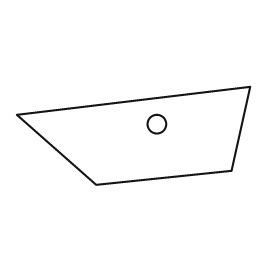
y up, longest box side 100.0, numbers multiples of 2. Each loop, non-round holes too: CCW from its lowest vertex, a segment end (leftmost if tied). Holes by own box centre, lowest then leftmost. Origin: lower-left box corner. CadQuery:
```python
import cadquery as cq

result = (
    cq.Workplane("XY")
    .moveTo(34.0, 0.0)
    .lineTo(92.0, 6.0)
    .lineTo(100.0, 42.0)
    .lineTo(0.0, 30.0)
    .close()
    .moveTo(60.0, 26.0)
    .circle(4.0)
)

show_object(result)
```